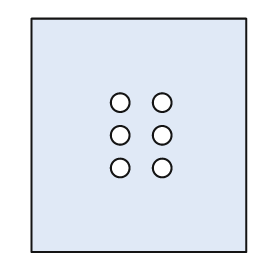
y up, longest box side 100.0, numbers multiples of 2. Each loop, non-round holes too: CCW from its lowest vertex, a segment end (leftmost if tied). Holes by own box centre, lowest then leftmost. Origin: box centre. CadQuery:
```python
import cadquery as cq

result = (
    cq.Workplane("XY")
    .moveTo(-46.0, -50.0)
    .lineTo(46.0, -50.0)
    .lineTo(46.0, 50.0)
    .lineTo(-46.0, 50.0)
    .close()
    .moveTo(-8.0, -14.0)
    .circle(4.0)
    .moveTo(10.0, -14.0)
    .circle(4.0)
    .moveTo(-8.0, 0.0)
    .circle(4.0)
    .moveTo(10.0, 0.0)
    .circle(4.0)
    .moveTo(-8.0, 14.0)
    .circle(4.0)
    .moveTo(10.0, 14.0)
    .circle(4.0)
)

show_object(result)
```